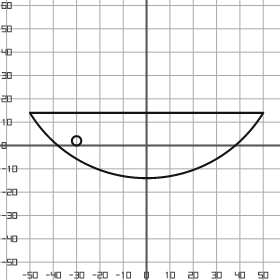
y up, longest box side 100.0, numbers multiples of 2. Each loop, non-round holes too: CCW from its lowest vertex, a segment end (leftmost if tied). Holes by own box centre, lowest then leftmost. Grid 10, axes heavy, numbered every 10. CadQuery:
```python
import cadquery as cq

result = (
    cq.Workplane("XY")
    .moveTo(-50.0, 14.0)
    .threePointArc((0.0, -14.0), (50.0, 14.0))
    .close()
    .moveTo(-30.0, 2.0)
    .circle(2.0)
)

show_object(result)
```